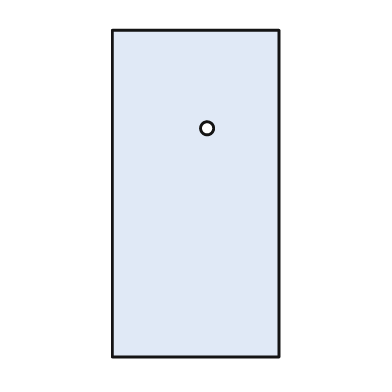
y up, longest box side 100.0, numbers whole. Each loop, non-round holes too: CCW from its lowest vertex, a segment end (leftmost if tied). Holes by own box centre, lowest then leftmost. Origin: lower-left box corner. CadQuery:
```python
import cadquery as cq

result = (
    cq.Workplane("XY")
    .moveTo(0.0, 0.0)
    .lineTo(51.0, 0.0)
    .lineTo(51.0, 100.0)
    .lineTo(0.0, 100.0)
    .close()
    .moveTo(29.0, 70.0)
    .circle(2.0)
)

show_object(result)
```